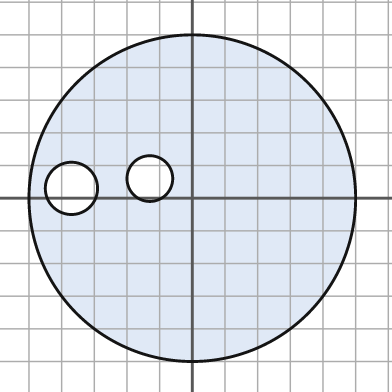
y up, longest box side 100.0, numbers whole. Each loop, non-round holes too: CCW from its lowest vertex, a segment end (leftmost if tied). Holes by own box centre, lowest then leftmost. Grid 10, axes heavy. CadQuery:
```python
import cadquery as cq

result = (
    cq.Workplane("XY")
    .moveTo(0.0, 0.0)
    .circle(50.0)
    .moveTo(-37.0, 3.0)
    .circle(8.0)
    .moveTo(-13.0, 6.0)
    .circle(7.0)
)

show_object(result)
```